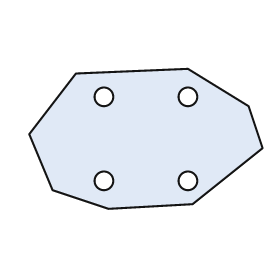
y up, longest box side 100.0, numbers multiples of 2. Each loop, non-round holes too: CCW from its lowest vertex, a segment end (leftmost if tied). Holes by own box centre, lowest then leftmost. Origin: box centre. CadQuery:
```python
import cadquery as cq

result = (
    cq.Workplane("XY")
    .moveTo(-16.0, -30.0)
    .lineTo(20.0, -28.0)
    .lineTo(50.0, -4.0)
    .lineTo(44.0, 14.0)
    .lineTo(18.0, 30.0)
    .lineTo(-30.0, 28.0)
    .lineTo(-50.0, 2.0)
    .lineTo(-40.0, -22.0)
    .close()
    .moveTo(-18.0, -18.0)
    .circle(4.0)
    .moveTo(18.0, -18.0)
    .circle(4.0)
    .moveTo(-18.0, 18.0)
    .circle(4.0)
    .moveTo(18.0, 18.0)
    .circle(4.0)
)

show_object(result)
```